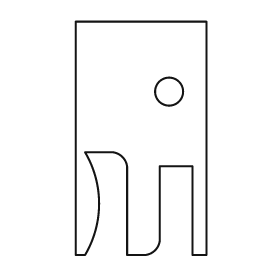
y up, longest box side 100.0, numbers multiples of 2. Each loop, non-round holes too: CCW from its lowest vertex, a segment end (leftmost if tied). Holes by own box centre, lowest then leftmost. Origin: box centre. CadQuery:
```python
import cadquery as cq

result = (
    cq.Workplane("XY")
    .moveTo(-28.0, -50.0)
    .lineTo(-24.0, -50.0)
    .threePointArc((-18.0, -28.0), (-24.0, -6.0))
    .lineTo(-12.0, -6.0)
    .threePointArc((-8.0, -8.0), (-6.0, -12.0))
    .lineTo(-6.0, -50.0)
    .lineTo(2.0, -50.0)
    .threePointArc((6.0, -48.0), (8.0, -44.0))
    .lineTo(8.0, -12.0)
    .lineTo(22.0, -12.0)
    .lineTo(22.0, -50.0)
    .lineTo(28.0, -50.0)
    .lineTo(28.0, 50.0)
    .lineTo(-28.0, 50.0)
    .close()
    .moveTo(12.0, 20.0)
    .circle(6.0)
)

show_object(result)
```